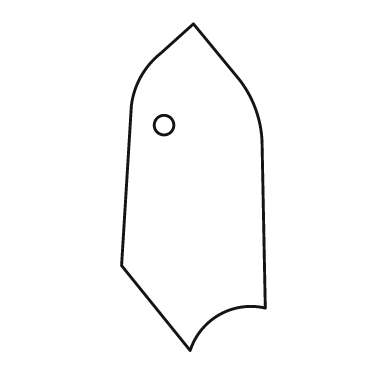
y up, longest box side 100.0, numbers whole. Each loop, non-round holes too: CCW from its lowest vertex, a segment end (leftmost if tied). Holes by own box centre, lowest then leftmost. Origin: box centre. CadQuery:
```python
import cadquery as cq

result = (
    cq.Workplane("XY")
    .moveTo(-1.0, -50.0)
    .threePointArc((8.0, -39.0), (22.0, -37.0))
    .lineTo(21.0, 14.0)
    .threePointArc((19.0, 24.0), (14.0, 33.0))
    .lineTo(0.0, 50.0)
    .lineTo(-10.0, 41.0)
    .threePointArc((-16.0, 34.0), (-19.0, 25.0))
    .lineTo(-22.0, -24.0)
    .close()
    .moveTo(-9.0, 19.0)
    .circle(3.0)
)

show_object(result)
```